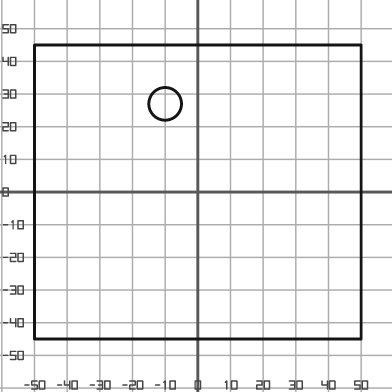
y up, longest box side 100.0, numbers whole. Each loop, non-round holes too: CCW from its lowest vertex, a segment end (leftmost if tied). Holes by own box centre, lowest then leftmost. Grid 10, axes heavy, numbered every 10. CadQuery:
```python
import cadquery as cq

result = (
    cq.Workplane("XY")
    .moveTo(-50.0, -45.0)
    .lineTo(50.0, -45.0)
    .lineTo(50.0, 45.0)
    .lineTo(-50.0, 45.0)
    .close()
    .moveTo(-10.0, 27.0)
    .circle(5.0)
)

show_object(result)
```